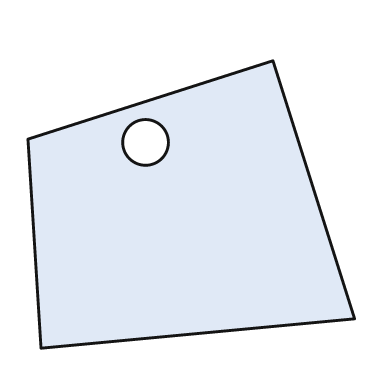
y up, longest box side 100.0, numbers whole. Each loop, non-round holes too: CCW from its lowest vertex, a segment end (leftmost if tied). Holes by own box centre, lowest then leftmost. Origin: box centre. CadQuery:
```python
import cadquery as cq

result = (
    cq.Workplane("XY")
    .moveTo(-46.0, -44.0)
    .lineTo(50.0, -35.0)
    .lineTo(25.0, 44.0)
    .lineTo(-50.0, 20.0)
    .close()
    .moveTo(-14.0, 19.0)
    .circle(7.0)
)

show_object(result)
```